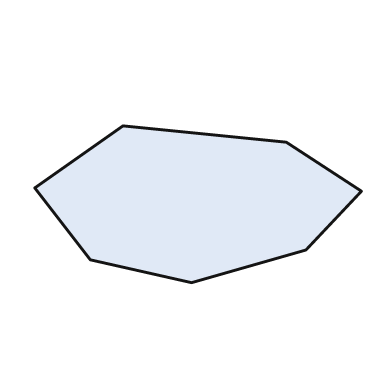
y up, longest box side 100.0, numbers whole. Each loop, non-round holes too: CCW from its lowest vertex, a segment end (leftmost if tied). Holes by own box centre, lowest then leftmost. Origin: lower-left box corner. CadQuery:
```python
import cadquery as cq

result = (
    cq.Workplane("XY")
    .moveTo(48.0, 0.0)
    .lineTo(83.0, 10.0)
    .lineTo(100.0, 28.0)
    .lineTo(77.0, 43.0)
    .lineTo(27.0, 48.0)
    .lineTo(0.0, 29.0)
    .lineTo(17.0, 7.0)
    .close()
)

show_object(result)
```